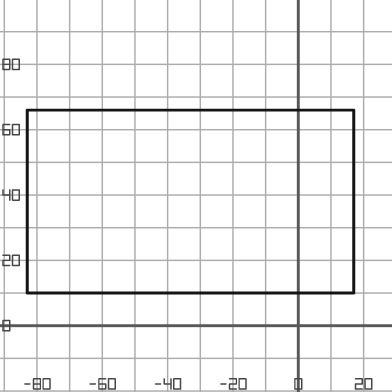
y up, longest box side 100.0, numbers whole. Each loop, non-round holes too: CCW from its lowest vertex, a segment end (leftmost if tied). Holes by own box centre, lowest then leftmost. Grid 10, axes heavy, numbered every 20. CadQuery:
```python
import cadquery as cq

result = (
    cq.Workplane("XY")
    .moveTo(-83.0, 10.0)
    .lineTo(17.0, 10.0)
    .lineTo(17.0, 66.0)
    .lineTo(-83.0, 66.0)
    .close()
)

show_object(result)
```